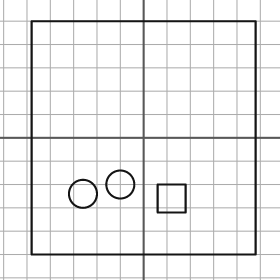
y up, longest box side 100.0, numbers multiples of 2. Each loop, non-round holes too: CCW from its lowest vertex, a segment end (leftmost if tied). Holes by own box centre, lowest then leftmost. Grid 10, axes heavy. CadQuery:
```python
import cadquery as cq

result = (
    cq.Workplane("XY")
    .moveTo(-48.0, -50.0)
    .lineTo(48.0, -50.0)
    .lineTo(48.0, 50.0)
    .lineTo(-48.0, 50.0)
    .close()
    .moveTo(6.0, -32.0)
    .lineTo(18.0, -32.0)
    .lineTo(18.0, -20.0)
    .lineTo(6.0, -20.0)
    .close()
    .moveTo(-26.0, -24.0)
    .circle(6.0)
    .moveTo(-10.0, -20.0)
    .circle(6.0)
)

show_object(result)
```